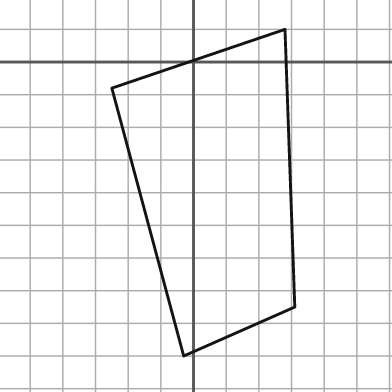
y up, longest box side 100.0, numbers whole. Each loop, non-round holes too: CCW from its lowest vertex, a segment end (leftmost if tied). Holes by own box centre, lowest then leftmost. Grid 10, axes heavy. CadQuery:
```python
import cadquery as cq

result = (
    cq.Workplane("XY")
    .moveTo(-3.0, -90.0)
    .lineTo(31.0, -75.0)
    .lineTo(28.0, 10.0)
    .lineTo(-25.0, -8.0)
    .close()
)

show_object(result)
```